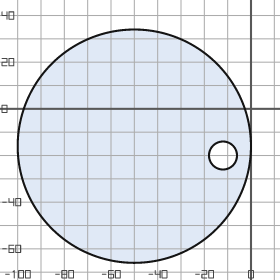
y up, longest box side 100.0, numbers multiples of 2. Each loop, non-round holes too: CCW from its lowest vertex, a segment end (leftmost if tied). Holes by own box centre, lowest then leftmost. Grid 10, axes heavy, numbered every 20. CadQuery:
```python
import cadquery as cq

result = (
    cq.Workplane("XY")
    .moveTo(-50.0, -16.0)
    .circle(50.0)
    .moveTo(-12.0, -20.0)
    .circle(6.0)
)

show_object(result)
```